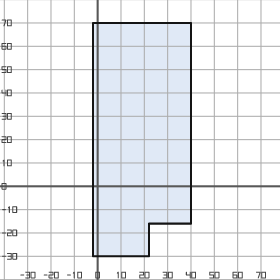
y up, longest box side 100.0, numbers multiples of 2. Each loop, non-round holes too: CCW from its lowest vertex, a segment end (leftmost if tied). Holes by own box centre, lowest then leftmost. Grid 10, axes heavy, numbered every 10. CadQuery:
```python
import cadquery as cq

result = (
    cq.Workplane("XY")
    .moveTo(-2.0, -30.0)
    .lineTo(22.0, -30.0)
    .lineTo(22.0, -16.0)
    .lineTo(40.0, -16.0)
    .lineTo(40.0, 70.0)
    .lineTo(-2.0, 70.0)
    .close()
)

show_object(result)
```